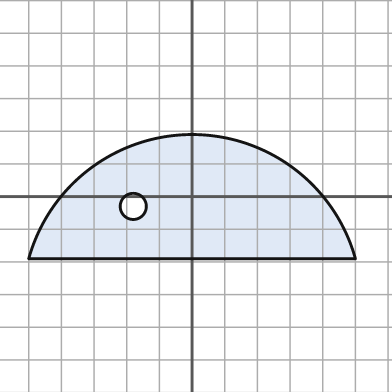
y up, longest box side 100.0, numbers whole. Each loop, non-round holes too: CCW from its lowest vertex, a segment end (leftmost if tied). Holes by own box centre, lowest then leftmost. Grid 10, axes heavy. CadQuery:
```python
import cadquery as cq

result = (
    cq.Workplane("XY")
    .moveTo(-50.0, -19.0)
    .lineTo(50.0, -19.0)
    .threePointArc((0.0, 19.0), (-50.0, -19.0))
    .close()
    .moveTo(-18.0, -3.0)
    .circle(4.0)
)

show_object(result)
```